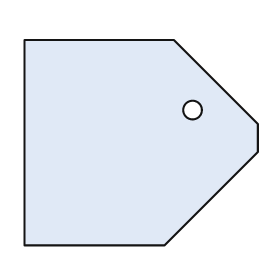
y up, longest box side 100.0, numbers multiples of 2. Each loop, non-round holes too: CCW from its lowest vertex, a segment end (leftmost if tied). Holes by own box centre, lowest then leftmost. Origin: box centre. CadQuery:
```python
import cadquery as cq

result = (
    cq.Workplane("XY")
    .moveTo(-50.0, -44.0)
    .lineTo(10.0, -44.0)
    .lineTo(50.0, -4.0)
    .lineTo(50.0, 8.0)
    .lineTo(14.0, 44.0)
    .lineTo(-50.0, 44.0)
    .close()
    .moveTo(22.0, 14.0)
    .circle(4.0)
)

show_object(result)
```